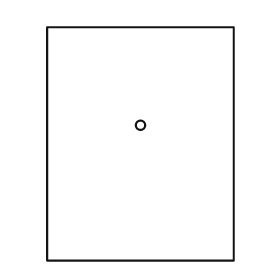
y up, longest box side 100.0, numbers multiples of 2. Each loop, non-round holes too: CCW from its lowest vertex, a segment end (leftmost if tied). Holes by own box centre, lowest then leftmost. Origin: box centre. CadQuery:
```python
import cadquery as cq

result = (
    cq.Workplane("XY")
    .moveTo(-40.0, -50.0)
    .lineTo(40.0, -50.0)
    .lineTo(40.0, 50.0)
    .lineTo(-40.0, 50.0)
    .close()
    .moveTo(0.0, 8.0)
    .circle(2.0)
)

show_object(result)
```